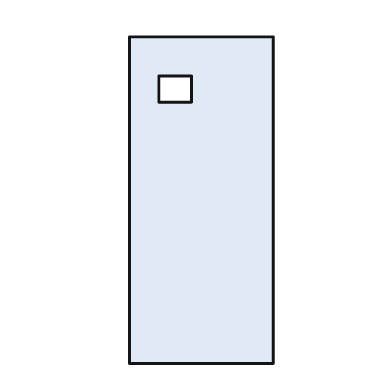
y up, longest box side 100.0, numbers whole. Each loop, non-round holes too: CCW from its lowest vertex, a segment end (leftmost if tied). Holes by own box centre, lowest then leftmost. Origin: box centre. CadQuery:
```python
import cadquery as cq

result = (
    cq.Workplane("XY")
    .moveTo(-22.0, -50.0)
    .lineTo(22.0, -50.0)
    .lineTo(22.0, 50.0)
    .lineTo(-22.0, 50.0)
    .close()
    .moveTo(-13.0, 30.0)
    .lineTo(-3.0, 30.0)
    .lineTo(-3.0, 38.0)
    .lineTo(-13.0, 38.0)
    .close()
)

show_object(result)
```